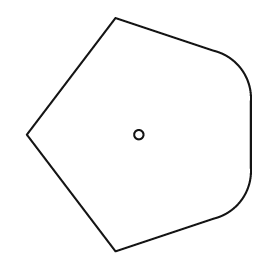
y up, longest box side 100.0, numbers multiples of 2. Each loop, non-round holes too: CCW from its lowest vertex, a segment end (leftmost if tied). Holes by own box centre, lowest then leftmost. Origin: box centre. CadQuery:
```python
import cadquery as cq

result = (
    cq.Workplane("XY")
    .moveTo(-10.0, -50.0)
    .lineTo(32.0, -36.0)
    .threePointArc((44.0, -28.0), (48.0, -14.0))
    .lineTo(48.0, 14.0)
    .threePointArc((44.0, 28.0), (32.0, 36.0))
    .lineTo(-10.0, 50.0)
    .lineTo(-48.0, 0.0)
    .close()
    .moveTo(0.0, 0.0)
    .circle(2.0)
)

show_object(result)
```